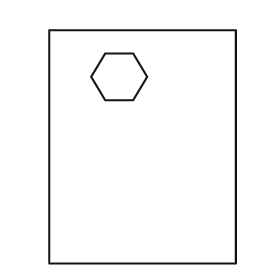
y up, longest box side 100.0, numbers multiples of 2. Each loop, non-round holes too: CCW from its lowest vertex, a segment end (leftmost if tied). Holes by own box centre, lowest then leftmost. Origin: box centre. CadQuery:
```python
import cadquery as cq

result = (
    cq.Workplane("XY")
    .moveTo(-40.0, -50.0)
    .lineTo(40.0, -50.0)
    .lineTo(40.0, 50.0)
    .lineTo(-40.0, 50.0)
    .close()
    .moveTo(-16.0, 20.0)
    .lineTo(-4.0, 20.0)
    .lineTo(2.0, 30.0)
    .lineTo(-4.0, 40.0)
    .lineTo(-16.0, 40.0)
    .lineTo(-22.0, 30.0)
    .close()
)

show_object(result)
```